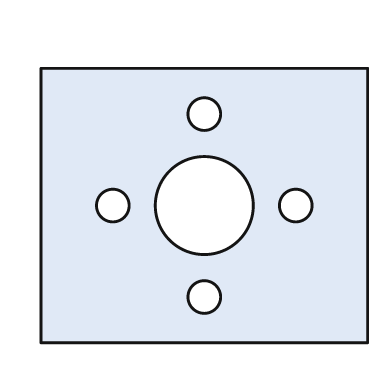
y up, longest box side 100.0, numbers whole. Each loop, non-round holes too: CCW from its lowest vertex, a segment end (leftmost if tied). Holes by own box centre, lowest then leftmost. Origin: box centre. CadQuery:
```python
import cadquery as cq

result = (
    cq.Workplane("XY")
    .moveTo(-50.0, -42.0)
    .lineTo(50.0, -42.0)
    .lineTo(50.0, 42.0)
    .lineTo(-50.0, 42.0)
    .close()
    .moveTo(0.0, -28.0)
    .circle(5.0)
    .moveTo(-28.0, 0.0)
    .circle(5.0)
    .moveTo(0.0, 0.0)
    .circle(15.0)
    .moveTo(28.0, 0.0)
    .circle(5.0)
    .moveTo(0.0, 28.0)
    .circle(5.0)
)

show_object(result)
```